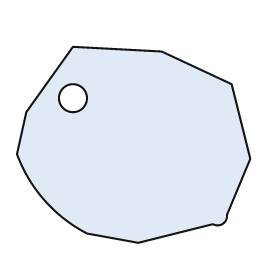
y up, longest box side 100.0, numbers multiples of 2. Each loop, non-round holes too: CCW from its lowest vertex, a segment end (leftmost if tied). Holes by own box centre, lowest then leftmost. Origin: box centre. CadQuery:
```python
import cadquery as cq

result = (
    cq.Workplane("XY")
    .moveTo(2.0, -42.0)
    .lineTo(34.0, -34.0)
    .threePointArc((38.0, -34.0), (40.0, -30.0))
    .lineTo(50.0, -6.0)
    .lineTo(42.0, 26.0)
    .lineTo(12.0, 40.0)
    .lineTo(-26.0, 42.0)
    .lineTo(-46.0, 14.0)
    .lineTo(-50.0, -4.0)
    .threePointArc((-38.0, -24.0), (-20.0, -38.0))
    .close()
    .moveTo(-26.0, 20.0)
    .circle(6.0)
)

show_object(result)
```